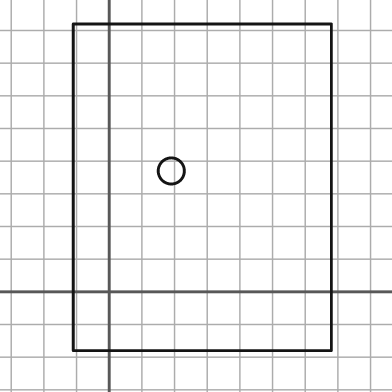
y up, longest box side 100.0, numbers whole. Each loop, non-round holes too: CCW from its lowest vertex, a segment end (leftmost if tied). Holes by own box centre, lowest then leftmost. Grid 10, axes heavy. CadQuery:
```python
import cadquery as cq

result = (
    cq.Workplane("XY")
    .moveTo(-11.0, -18.0)
    .lineTo(68.0, -18.0)
    .lineTo(68.0, 82.0)
    .lineTo(-11.0, 82.0)
    .close()
    .moveTo(19.0, 37.0)
    .circle(4.0)
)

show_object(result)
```